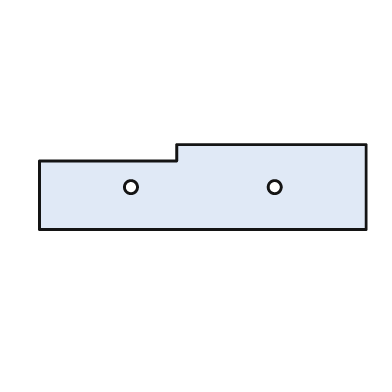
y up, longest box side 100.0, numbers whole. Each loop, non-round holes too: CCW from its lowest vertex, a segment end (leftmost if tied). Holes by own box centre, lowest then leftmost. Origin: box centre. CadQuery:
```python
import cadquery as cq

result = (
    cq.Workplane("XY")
    .moveTo(-50.0, -13.0)
    .lineTo(50.0, -13.0)
    .lineTo(50.0, 13.0)
    .lineTo(-8.0, 13.0)
    .lineTo(-8.0, 8.0)
    .lineTo(-50.0, 8.0)
    .close()
    .moveTo(-22.0, 0.0)
    .circle(2.0)
    .moveTo(22.0, 0.0)
    .circle(2.0)
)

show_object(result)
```